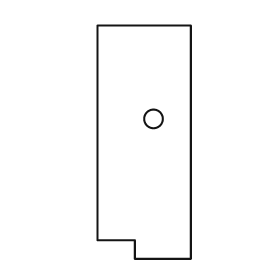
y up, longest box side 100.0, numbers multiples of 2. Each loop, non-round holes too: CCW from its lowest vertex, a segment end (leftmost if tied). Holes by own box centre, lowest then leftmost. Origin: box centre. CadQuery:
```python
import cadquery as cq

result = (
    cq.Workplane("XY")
    .moveTo(-4.0, -50.0)
    .lineTo(20.0, -50.0)
    .lineTo(20.0, 50.0)
    .lineTo(-20.0, 50.0)
    .lineTo(-20.0, -42.0)
    .lineTo(-4.0, -42.0)
    .close()
    .moveTo(4.0, 10.0)
    .circle(4.0)
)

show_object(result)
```